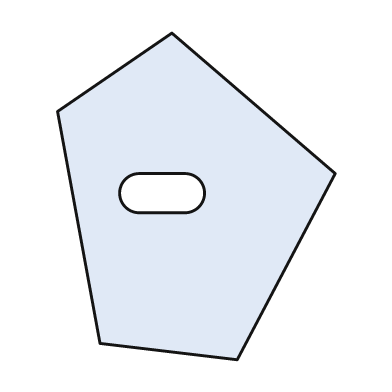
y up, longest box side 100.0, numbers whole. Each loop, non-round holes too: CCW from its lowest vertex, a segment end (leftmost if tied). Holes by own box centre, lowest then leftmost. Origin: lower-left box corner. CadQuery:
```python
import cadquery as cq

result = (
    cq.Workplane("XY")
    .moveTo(55.0, 0.0)
    .lineTo(85.0, 57.0)
    .lineTo(35.0, 100.0)
    .lineTo(0.0, 76.0)
    .lineTo(13.0, 5.0)
    .close()
    .moveTo(25.0, 45.0)
    .lineTo(39.0, 45.0)
    .threePointArc((45.0, 51.0), (39.0, 57.0))
    .lineTo(25.0, 57.0)
    .threePointArc((19.0, 51.0), (25.0, 45.0))
    .close()
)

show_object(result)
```